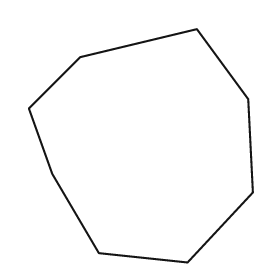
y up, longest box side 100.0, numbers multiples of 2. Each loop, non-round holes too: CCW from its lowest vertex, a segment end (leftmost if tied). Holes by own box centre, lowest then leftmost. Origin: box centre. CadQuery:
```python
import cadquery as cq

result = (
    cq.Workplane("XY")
    .moveTo(20.0, -50.0)
    .lineTo(48.0, -20.0)
    .lineTo(46.0, 20.0)
    .lineTo(24.0, 50.0)
    .lineTo(-26.0, 38.0)
    .lineTo(-48.0, 16.0)
    .lineTo(-38.0, -12.0)
    .lineTo(-18.0, -46.0)
    .close()
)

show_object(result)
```